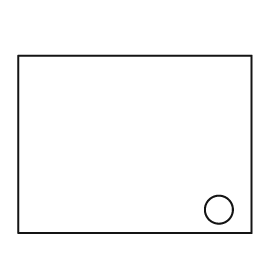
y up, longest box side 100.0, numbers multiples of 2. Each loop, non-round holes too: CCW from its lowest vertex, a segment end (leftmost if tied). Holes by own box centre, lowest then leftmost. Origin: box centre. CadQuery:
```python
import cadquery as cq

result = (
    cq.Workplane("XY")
    .moveTo(-50.0, -38.0)
    .lineTo(50.0, -38.0)
    .lineTo(50.0, 38.0)
    .lineTo(-50.0, 38.0)
    .close()
    .moveTo(36.0, -28.0)
    .circle(6.0)
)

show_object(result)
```